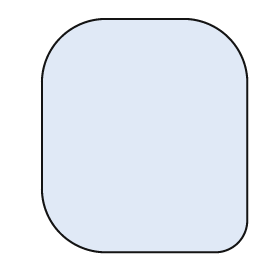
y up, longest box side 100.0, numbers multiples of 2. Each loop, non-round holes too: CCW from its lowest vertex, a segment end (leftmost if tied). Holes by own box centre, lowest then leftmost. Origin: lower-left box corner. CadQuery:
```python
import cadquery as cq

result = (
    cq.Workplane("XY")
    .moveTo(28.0, 0.0)
    .lineTo(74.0, 0.0)
    .threePointArc((84.0, 4.0), (88.0, 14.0))
    .lineTo(88.0, 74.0)
    .threePointArc((80.0, 92.0), (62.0, 100.0))
    .lineTo(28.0, 100.0)
    .threePointArc((8.0, 92.0), (0.0, 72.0))
    .lineTo(0.0, 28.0)
    .threePointArc((8.0, 8.0), (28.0, 0.0))
    .close()
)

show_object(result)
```